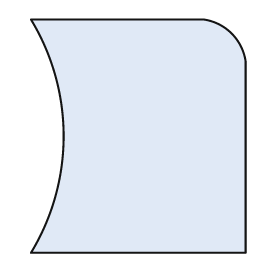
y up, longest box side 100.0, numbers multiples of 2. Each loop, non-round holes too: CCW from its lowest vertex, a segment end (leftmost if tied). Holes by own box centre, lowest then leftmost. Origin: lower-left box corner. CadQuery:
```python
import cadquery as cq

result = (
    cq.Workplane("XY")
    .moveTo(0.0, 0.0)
    .lineTo(92.0, 0.0)
    .lineTo(92.0, 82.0)
    .threePointArc((86.0, 94.0), (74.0, 100.0))
    .lineTo(0.0, 100.0)
    .threePointArc((14.0, 50.0), (0.0, 0.0))
    .close()
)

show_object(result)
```